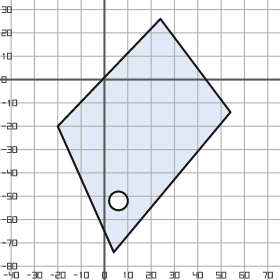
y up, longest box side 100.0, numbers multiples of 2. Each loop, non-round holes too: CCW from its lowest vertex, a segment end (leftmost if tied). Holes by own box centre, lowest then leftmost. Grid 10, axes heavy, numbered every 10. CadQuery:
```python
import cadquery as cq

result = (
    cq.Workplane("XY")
    .moveTo(4.0, -74.0)
    .lineTo(54.0, -14.0)
    .lineTo(24.0, 26.0)
    .lineTo(-20.0, -20.0)
    .close()
    .moveTo(6.0, -52.0)
    .circle(4.0)
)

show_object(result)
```